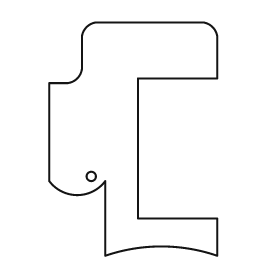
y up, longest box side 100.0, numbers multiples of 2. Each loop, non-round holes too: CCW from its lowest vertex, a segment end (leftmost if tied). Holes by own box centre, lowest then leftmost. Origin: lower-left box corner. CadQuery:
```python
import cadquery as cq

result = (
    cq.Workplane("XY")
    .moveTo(24.0, 0.0)
    .threePointArc((48.0, 4.0), (72.0, 0.0))
    .lineTo(72.0, 16.0)
    .lineTo(38.0, 16.0)
    .lineTo(38.0, 76.0)
    .lineTo(72.0, 76.0)
    .lineTo(72.0, 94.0)
    .threePointArc((70.0, 98.0), (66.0, 100.0))
    .lineTo(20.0, 100.0)
    .threePointArc((16.0, 98.0), (14.0, 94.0))
    .lineTo(14.0, 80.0)
    .threePointArc((12.0, 76.0), (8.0, 74.0))
    .lineTo(0.0, 74.0)
    .lineTo(0.0, 32.0)
    .threePointArc((12.0, 26.0), (24.0, 32.0))
    .close()
    .moveTo(18.0, 34.0)
    .circle(2.0)
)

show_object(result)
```